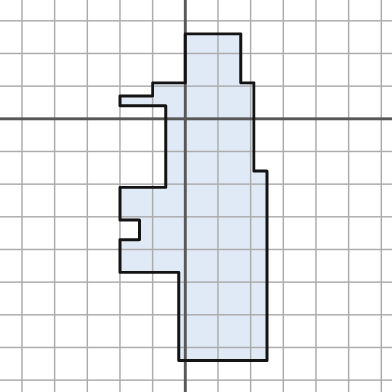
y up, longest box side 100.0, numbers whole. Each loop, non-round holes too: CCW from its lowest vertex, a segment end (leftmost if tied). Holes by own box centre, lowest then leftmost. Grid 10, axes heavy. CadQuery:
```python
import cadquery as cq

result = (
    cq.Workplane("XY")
    .moveTo(-2.0, -74.0)
    .lineTo(25.0, -74.0)
    .lineTo(25.0, -16.0)
    .lineTo(21.0, -16.0)
    .lineTo(21.0, 11.0)
    .lineTo(17.0, 11.0)
    .lineTo(17.0, 26.0)
    .lineTo(0.0, 26.0)
    .lineTo(0.0, 11.0)
    .lineTo(-10.0, 11.0)
    .lineTo(-10.0, 7.0)
    .lineTo(-20.0, 7.0)
    .lineTo(-20.0, 4.0)
    .lineTo(-6.0, 4.0)
    .lineTo(-6.0, -21.0)
    .lineTo(-20.0, -21.0)
    .lineTo(-20.0, -31.0)
    .lineTo(-14.0, -31.0)
    .lineTo(-14.0, -37.0)
    .lineTo(-20.0, -37.0)
    .lineTo(-20.0, -47.0)
    .lineTo(-2.0, -47.0)
    .close()
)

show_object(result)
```